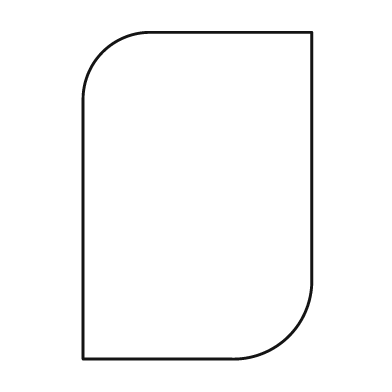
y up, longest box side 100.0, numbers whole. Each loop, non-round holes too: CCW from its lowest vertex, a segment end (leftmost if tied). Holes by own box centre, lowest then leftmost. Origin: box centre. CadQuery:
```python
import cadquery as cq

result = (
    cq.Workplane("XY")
    .moveTo(-35.0, -50.0)
    .lineTo(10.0, -50.0)
    .threePointArc((28.0, -43.0), (35.0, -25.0))
    .lineTo(35.0, 50.0)
    .lineTo(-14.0, 50.0)
    .threePointArc((-29.0, 44.0), (-35.0, 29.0))
    .close()
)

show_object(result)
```